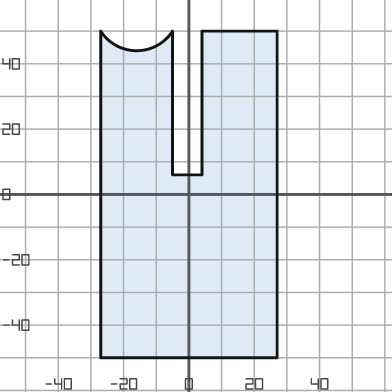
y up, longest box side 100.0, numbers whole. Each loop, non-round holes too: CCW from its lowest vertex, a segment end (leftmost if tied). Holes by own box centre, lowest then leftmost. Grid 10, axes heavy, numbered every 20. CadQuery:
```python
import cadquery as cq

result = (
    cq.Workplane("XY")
    .moveTo(-27.0, -50.0)
    .lineTo(27.0, -50.0)
    .lineTo(27.0, 50.0)
    .lineTo(4.0, 50.0)
    .lineTo(4.0, 6.0)
    .lineTo(-5.0, 6.0)
    .lineTo(-5.0, 50.0)
    .threePointArc((-16.0, 44.0), (-27.0, 50.0))
    .close()
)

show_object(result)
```